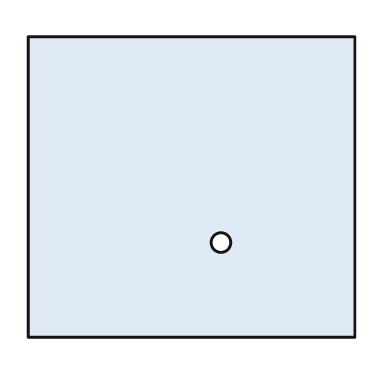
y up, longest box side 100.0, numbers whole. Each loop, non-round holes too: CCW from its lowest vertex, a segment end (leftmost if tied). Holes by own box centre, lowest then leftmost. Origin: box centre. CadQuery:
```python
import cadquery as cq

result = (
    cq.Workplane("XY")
    .moveTo(-50.0, -46.0)
    .lineTo(50.0, -46.0)
    .lineTo(50.0, 46.0)
    .lineTo(-50.0, 46.0)
    .close()
    .moveTo(9.0, -17.0)
    .circle(3.0)
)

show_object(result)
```